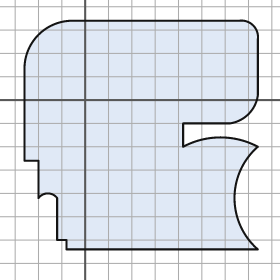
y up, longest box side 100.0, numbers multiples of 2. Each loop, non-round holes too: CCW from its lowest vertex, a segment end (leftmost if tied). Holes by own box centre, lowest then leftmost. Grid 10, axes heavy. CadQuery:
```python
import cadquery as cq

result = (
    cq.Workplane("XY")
    .moveTo(-8.0, -64.0)
    .lineTo(74.0, -64.0)
    .threePointArc((64.0, -42.0), (74.0, -20.0))
    .threePointArc((58.0, -16.0), (42.0, -20.0))
    .lineTo(42.0, -10.0)
    .lineTo(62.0, -10.0)
    .threePointArc((70.0, -6.0), (74.0, 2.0))
    .lineTo(74.0, 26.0)
    .threePointArc((72.0, 32.0), (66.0, 34.0))
    .lineTo(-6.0, 34.0)
    .threePointArc((-20.0, 28.0), (-26.0, 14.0))
    .lineTo(-26.0, -26.0)
    .lineTo(-20.0, -26.0)
    .lineTo(-20.0, -42.0)
    .threePointArc((-16.0, -40.0), (-12.0, -42.0))
    .lineTo(-12.0, -60.0)
    .lineTo(-8.0, -60.0)
    .close()
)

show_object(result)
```